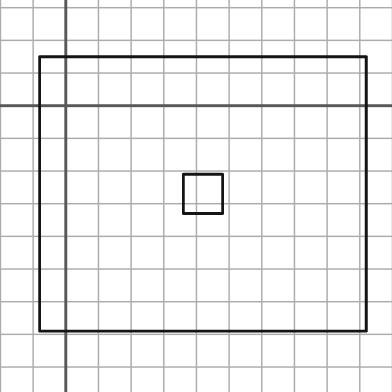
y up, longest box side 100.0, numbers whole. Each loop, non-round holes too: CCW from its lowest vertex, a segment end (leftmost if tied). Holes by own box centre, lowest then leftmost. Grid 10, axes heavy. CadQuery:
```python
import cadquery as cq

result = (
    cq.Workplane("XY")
    .moveTo(-8.0, -69.0)
    .lineTo(92.0, -69.0)
    .lineTo(92.0, 15.0)
    .lineTo(-8.0, 15.0)
    .close()
    .moveTo(36.0, -33.0)
    .lineTo(48.0, -33.0)
    .lineTo(48.0, -21.0)
    .lineTo(36.0, -21.0)
    .close()
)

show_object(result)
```